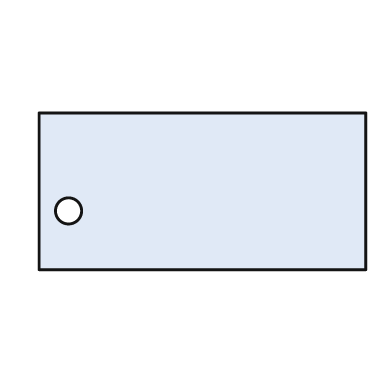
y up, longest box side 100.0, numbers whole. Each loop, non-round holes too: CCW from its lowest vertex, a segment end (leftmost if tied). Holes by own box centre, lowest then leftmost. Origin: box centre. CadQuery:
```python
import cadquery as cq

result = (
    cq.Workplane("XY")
    .moveTo(-50.0, -24.0)
    .lineTo(50.0, -24.0)
    .lineTo(50.0, 24.0)
    .lineTo(-50.0, 24.0)
    .close()
    .moveTo(-41.0, -6.0)
    .circle(4.0)
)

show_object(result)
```